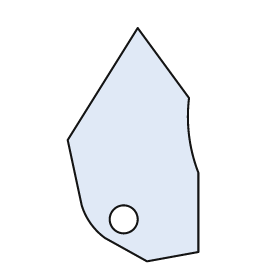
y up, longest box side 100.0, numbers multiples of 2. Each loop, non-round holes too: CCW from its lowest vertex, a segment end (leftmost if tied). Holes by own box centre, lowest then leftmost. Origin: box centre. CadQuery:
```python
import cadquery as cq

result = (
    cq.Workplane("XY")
    .moveTo(6.0, -50.0)
    .lineTo(28.0, -46.0)
    .lineTo(28.0, -12.0)
    .threePointArc((24.0, 4.0), (24.0, 20.0))
    .lineTo(2.0, 50.0)
    .lineTo(-28.0, 2.0)
    .lineTo(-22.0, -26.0)
    .threePointArc((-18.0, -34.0), (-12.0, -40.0))
    .close()
    .moveTo(-4.0, -32.0)
    .circle(6.0)
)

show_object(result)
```